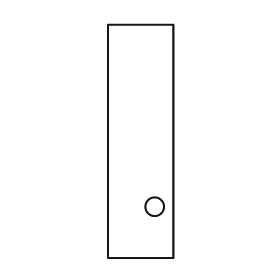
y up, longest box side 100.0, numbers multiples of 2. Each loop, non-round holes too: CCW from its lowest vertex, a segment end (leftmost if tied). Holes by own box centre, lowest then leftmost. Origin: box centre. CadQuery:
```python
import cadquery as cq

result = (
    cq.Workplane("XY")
    .moveTo(-14.0, -50.0)
    .lineTo(14.0, -50.0)
    .lineTo(14.0, 50.0)
    .lineTo(-14.0, 50.0)
    .close()
    .moveTo(6.0, -28.0)
    .circle(4.0)
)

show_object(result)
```